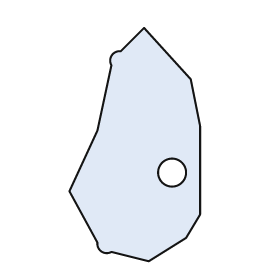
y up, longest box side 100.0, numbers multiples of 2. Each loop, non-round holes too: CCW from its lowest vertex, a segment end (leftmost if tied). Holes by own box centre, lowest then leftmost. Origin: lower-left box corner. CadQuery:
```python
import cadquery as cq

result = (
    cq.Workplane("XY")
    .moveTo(34.0, 0.0)
    .lineTo(50.0, 10.0)
    .lineTo(56.0, 20.0)
    .lineTo(56.0, 58.0)
    .lineTo(52.0, 78.0)
    .lineTo(32.0, 100.0)
    .lineTo(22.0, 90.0)
    .threePointArc((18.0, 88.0), (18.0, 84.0))
    .lineTo(12.0, 56.0)
    .lineTo(0.0, 30.0)
    .lineTo(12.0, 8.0)
    .threePointArc((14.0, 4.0), (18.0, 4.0))
    .close()
    .moveTo(44.0, 38.0)
    .circle(6.0)
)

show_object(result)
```